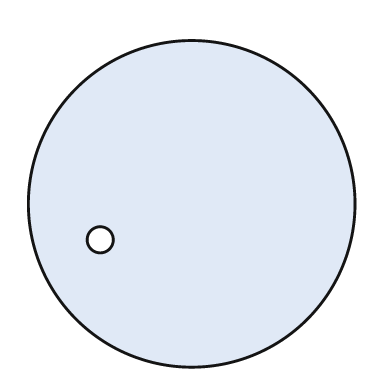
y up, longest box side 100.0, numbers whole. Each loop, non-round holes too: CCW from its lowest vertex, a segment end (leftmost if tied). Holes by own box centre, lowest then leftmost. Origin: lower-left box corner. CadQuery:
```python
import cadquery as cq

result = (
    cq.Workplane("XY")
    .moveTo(50.0, 50.0)
    .circle(50.0)
    .moveTo(22.0, 39.0)
    .circle(4.0)
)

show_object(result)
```